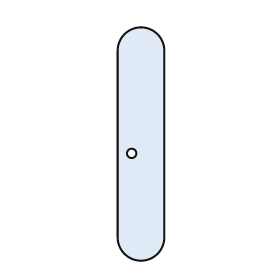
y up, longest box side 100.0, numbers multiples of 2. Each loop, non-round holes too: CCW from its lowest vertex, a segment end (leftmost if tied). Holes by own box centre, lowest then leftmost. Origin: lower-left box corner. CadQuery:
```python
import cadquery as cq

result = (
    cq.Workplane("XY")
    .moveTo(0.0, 10.0)
    .threePointArc((10.0, 0.0), (20.0, 10.0))
    .lineTo(20.0, 90.0)
    .threePointArc((10.0, 100.0), (0.0, 90.0))
    .close()
    .moveTo(6.0, 46.0)
    .circle(2.0)
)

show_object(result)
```